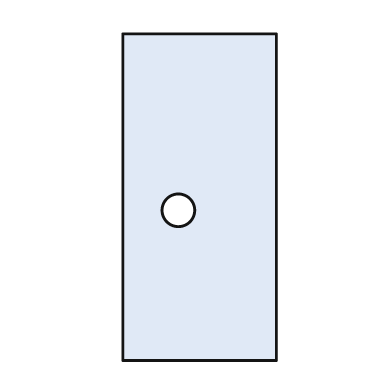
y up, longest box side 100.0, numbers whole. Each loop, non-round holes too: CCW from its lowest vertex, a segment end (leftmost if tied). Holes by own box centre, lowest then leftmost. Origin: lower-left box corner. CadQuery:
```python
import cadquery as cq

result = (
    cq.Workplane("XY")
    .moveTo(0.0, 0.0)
    .lineTo(47.0, 0.0)
    .lineTo(47.0, 100.0)
    .lineTo(0.0, 100.0)
    .close()
    .moveTo(17.0, 46.0)
    .circle(5.0)
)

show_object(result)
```